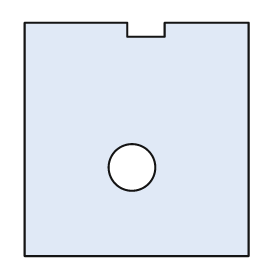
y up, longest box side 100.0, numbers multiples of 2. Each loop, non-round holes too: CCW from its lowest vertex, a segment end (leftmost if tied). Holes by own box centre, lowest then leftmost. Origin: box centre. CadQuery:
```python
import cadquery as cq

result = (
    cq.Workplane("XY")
    .moveTo(-48.0, -50.0)
    .lineTo(48.0, -50.0)
    .lineTo(48.0, 50.0)
    .lineTo(12.0, 50.0)
    .lineTo(12.0, 44.0)
    .lineTo(-4.0, 44.0)
    .lineTo(-4.0, 50.0)
    .lineTo(-48.0, 50.0)
    .close()
    .moveTo(-2.0, -12.0)
    .circle(10.0)
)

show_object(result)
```